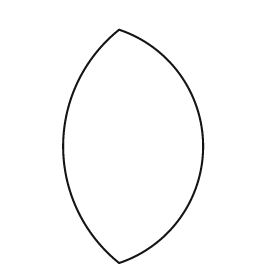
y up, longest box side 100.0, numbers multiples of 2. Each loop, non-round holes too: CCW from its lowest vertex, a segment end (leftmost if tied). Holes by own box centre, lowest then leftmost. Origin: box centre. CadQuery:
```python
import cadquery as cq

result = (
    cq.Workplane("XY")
    .moveTo(-6.0, -50.0)
    .threePointArc((30.0, 0.0), (-6.0, 50.0))
    .threePointArc((-30.0, 0.0), (-6.0, -50.0))
    .close()
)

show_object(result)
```